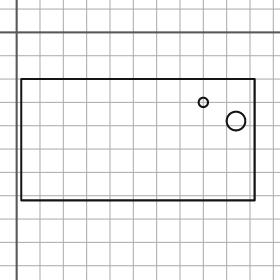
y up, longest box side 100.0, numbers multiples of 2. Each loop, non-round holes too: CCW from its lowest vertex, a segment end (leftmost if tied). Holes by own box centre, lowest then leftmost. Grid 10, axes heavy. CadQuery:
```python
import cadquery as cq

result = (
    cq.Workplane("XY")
    .moveTo(2.0, -72.0)
    .lineTo(102.0, -72.0)
    .lineTo(102.0, -20.0)
    .lineTo(2.0, -20.0)
    .close()
    .moveTo(94.0, -38.0)
    .circle(4.0)
    .moveTo(80.0, -30.0)
    .circle(2.0)
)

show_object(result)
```